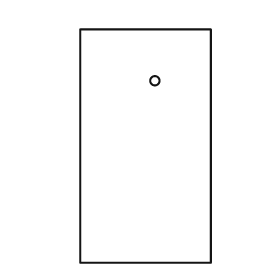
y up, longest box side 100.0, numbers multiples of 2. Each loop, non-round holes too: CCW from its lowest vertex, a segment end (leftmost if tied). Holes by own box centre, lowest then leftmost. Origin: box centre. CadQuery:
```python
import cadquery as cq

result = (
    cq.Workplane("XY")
    .moveTo(-28.0, -50.0)
    .lineTo(28.0, -50.0)
    .lineTo(28.0, 50.0)
    .lineTo(-28.0, 50.0)
    .close()
    .moveTo(4.0, 28.0)
    .circle(2.0)
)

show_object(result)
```